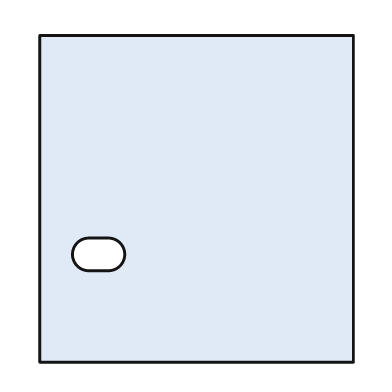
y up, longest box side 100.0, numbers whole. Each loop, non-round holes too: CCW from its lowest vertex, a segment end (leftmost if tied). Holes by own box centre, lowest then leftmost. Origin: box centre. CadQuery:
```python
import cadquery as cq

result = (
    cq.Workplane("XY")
    .moveTo(-48.0, -50.0)
    .lineTo(48.0, -50.0)
    .lineTo(48.0, 50.0)
    .lineTo(-48.0, 50.0)
    .close()
    .moveTo(-33.0, -22.0)
    .lineTo(-27.0, -22.0)
    .threePointArc((-22.0, -17.0), (-27.0, -12.0))
    .lineTo(-33.0, -12.0)
    .threePointArc((-38.0, -17.0), (-33.0, -22.0))
    .close()
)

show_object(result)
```